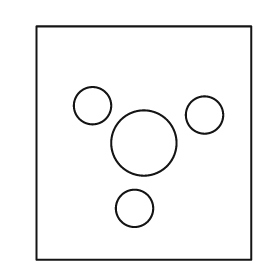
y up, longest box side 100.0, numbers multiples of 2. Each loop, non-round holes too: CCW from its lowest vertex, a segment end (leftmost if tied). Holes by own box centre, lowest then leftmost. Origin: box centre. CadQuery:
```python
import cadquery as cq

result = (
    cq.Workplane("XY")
    .moveTo(-46.0, -50.0)
    .lineTo(46.0, -50.0)
    .lineTo(46.0, 50.0)
    .lineTo(-46.0, 50.0)
    .close()
    .moveTo(-4.0, -28.0)
    .circle(8.0)
    .moveTo(0.0, 0.0)
    .circle(14.0)
    .moveTo(26.0, 12.0)
    .circle(8.0)
    .moveTo(-22.0, 16.0)
    .circle(8.0)
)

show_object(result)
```